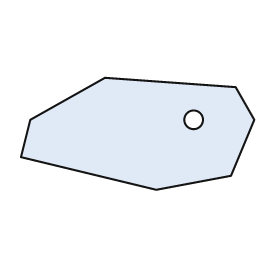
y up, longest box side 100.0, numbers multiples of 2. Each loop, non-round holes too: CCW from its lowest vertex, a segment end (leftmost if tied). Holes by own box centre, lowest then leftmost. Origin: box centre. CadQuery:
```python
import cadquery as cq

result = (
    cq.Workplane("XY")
    .moveTo(8.0, -24.0)
    .lineTo(40.0, -18.0)
    .lineTo(50.0, 6.0)
    .lineTo(42.0, 20.0)
    .lineTo(-14.0, 24.0)
    .lineTo(-46.0, 6.0)
    .lineTo(-50.0, -10.0)
    .close()
    .moveTo(24.0, 6.0)
    .circle(4.0)
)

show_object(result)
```